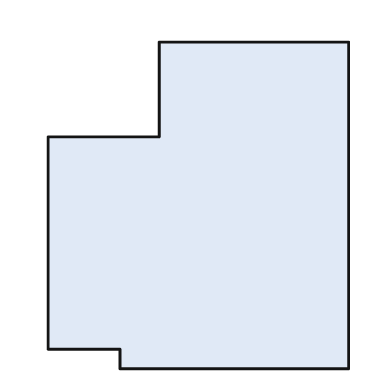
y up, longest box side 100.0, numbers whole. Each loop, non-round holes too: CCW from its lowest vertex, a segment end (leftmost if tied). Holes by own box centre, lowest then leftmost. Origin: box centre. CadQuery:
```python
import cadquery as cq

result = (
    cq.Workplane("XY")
    .moveTo(-24.0, -50.0)
    .lineTo(46.0, -50.0)
    .lineTo(46.0, 50.0)
    .lineTo(-12.0, 50.0)
    .lineTo(-12.0, 21.0)
    .lineTo(-46.0, 21.0)
    .lineTo(-46.0, -44.0)
    .lineTo(-24.0, -44.0)
    .close()
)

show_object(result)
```